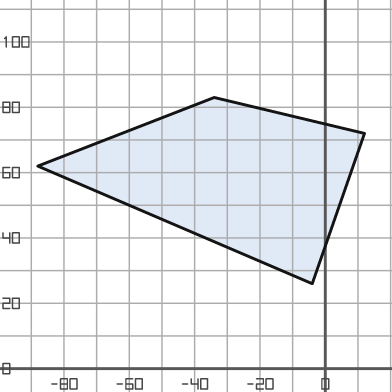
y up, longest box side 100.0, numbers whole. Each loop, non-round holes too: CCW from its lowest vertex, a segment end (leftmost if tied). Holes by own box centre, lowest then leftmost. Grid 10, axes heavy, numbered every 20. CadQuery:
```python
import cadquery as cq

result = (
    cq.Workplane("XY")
    .moveTo(-4.0, 26.0)
    .lineTo(12.0, 72.0)
    .lineTo(-34.0, 83.0)
    .lineTo(-88.0, 62.0)
    .close()
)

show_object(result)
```